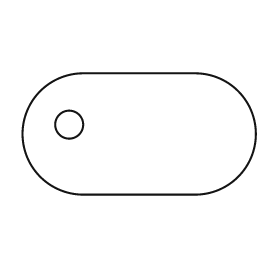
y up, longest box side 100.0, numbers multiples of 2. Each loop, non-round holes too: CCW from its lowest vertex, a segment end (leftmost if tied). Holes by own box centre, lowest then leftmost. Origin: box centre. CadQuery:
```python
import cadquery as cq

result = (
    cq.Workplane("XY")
    .moveTo(-24.0, -26.0)
    .lineTo(24.0, -26.0)
    .threePointArc((50.0, 0.0), (24.0, 26.0))
    .lineTo(-24.0, 26.0)
    .threePointArc((-50.0, 0.0), (-24.0, -26.0))
    .close()
    .moveTo(-30.0, 4.0)
    .circle(6.0)
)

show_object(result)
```